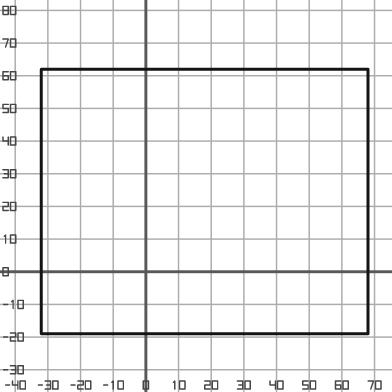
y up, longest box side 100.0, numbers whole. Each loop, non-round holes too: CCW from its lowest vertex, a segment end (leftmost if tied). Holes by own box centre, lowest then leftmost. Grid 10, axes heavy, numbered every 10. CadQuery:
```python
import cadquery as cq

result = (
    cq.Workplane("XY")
    .moveTo(-32.0, -19.0)
    .lineTo(68.0, -19.0)
    .lineTo(68.0, 62.0)
    .lineTo(-32.0, 62.0)
    .close()
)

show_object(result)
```